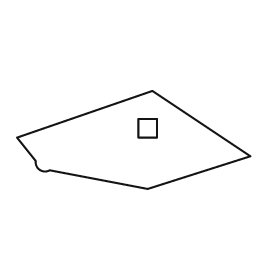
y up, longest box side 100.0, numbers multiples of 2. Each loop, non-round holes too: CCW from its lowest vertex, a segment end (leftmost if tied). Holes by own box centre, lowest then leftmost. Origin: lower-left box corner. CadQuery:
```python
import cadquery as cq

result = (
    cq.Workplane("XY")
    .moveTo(56.0, 0.0)
    .lineTo(100.0, 14.0)
    .lineTo(58.0, 42.0)
    .lineTo(0.0, 22.0)
    .lineTo(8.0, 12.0)
    .threePointArc((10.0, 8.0), (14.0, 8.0))
    .close()
    .moveTo(52.0, 22.0)
    .lineTo(60.0, 22.0)
    .lineTo(60.0, 30.0)
    .lineTo(52.0, 30.0)
    .close()
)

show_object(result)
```